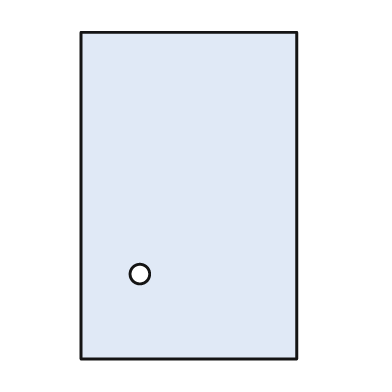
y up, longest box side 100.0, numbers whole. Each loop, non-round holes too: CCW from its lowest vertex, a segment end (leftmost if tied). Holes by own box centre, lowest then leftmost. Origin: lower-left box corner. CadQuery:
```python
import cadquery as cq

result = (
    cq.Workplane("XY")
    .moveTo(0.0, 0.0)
    .lineTo(66.0, 0.0)
    .lineTo(66.0, 100.0)
    .lineTo(0.0, 100.0)
    .close()
    .moveTo(18.0, 26.0)
    .circle(3.0)
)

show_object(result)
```